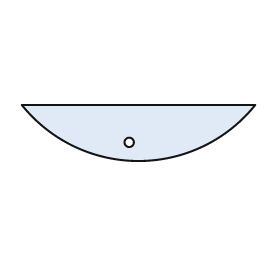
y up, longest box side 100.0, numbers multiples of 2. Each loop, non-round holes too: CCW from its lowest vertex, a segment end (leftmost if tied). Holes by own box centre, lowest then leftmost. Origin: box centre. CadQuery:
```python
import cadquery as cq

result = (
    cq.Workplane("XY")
    .moveTo(-50.0, 12.0)
    .threePointArc((0.0, -12.0), (50.0, 12.0))
    .close()
    .moveTo(-4.0, -4.0)
    .circle(2.0)
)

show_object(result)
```